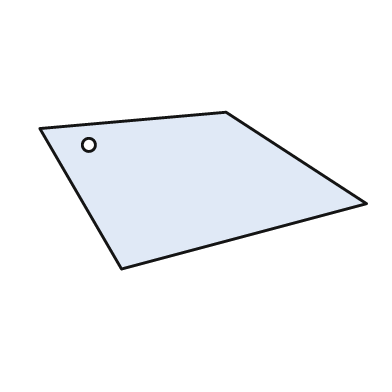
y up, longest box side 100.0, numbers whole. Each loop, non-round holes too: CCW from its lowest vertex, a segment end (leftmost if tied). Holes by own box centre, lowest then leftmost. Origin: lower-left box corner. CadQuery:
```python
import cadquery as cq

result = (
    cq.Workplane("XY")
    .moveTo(25.0, 0.0)
    .lineTo(100.0, 20.0)
    .lineTo(57.0, 48.0)
    .lineTo(0.0, 43.0)
    .close()
    .moveTo(15.0, 38.0)
    .circle(2.0)
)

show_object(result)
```